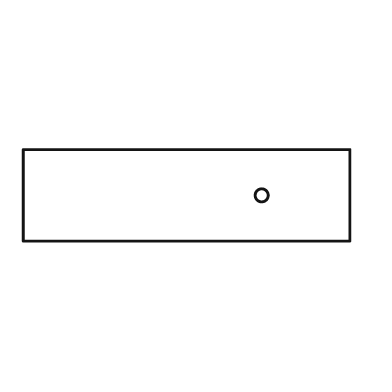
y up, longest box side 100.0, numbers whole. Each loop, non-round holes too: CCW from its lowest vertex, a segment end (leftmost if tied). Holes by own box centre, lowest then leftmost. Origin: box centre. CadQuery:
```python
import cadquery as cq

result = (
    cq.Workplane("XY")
    .moveTo(-50.0, -14.0)
    .lineTo(50.0, -14.0)
    .lineTo(50.0, 14.0)
    .lineTo(-50.0, 14.0)
    .close()
    .moveTo(23.0, 0.0)
    .circle(2.0)
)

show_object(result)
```